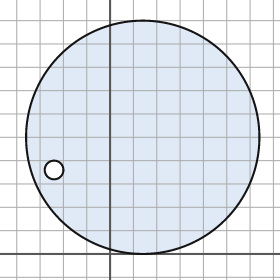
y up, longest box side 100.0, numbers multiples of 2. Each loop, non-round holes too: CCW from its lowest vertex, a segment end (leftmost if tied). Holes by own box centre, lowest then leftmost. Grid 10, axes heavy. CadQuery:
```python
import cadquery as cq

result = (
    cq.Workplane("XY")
    .moveTo(14.0, 50.0)
    .circle(50.0)
    .moveTo(-24.0, 36.0)
    .circle(4.0)
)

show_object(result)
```